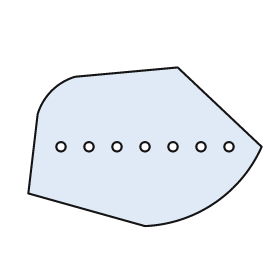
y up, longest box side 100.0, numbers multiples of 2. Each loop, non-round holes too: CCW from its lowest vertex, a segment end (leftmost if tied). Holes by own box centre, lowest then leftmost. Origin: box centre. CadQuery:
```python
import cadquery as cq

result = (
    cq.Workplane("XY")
    .moveTo(0.0, -34.0)
    .threePointArc((30.0, -24.0), (50.0, 0.0))
    .lineTo(14.0, 34.0)
    .lineTo(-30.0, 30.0)
    .threePointArc((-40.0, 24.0), (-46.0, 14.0))
    .lineTo(-50.0, -20.0)
    .close()
    .moveTo(-36.0, 0.0)
    .circle(2.0)
    .moveTo(-24.0, 0.0)
    .circle(2.0)
    .moveTo(-12.0, 0.0)
    .circle(2.0)
    .moveTo(0.0, 0.0)
    .circle(2.0)
    .moveTo(12.0, 0.0)
    .circle(2.0)
    .moveTo(24.0, 0.0)
    .circle(2.0)
    .moveTo(36.0, 0.0)
    .circle(2.0)
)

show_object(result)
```